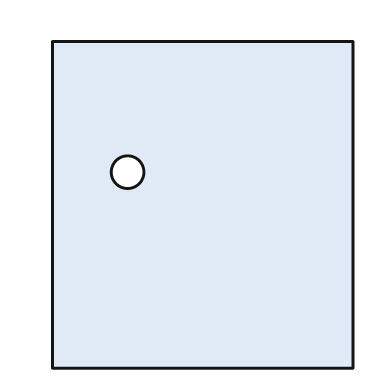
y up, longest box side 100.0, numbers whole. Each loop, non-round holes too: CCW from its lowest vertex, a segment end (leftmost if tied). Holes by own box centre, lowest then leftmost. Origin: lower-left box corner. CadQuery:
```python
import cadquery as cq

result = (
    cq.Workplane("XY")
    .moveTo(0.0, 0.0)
    .lineTo(92.0, 0.0)
    .lineTo(92.0, 100.0)
    .lineTo(0.0, 100.0)
    .close()
    .moveTo(23.0, 60.0)
    .circle(5.0)
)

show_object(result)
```